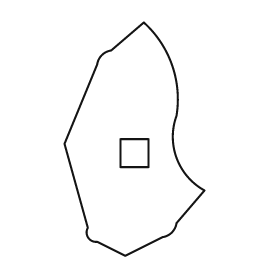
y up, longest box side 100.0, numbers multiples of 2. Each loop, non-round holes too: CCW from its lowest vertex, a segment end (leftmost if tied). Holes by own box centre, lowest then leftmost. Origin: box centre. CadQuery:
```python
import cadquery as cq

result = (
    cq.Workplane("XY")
    .moveTo(-4.0, -50.0)
    .lineTo(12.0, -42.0)
    .threePointArc((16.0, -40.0), (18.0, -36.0))
    .lineTo(30.0, -22.0)
    .threePointArc((18.0, -8.0), (18.0, 10.0))
    .threePointArc((16.0, 32.0), (4.0, 50.0))
    .lineTo(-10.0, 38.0)
    .threePointArc((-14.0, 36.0), (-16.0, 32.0))
    .lineTo(-30.0, -2.0)
    .lineTo(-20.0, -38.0)
    .threePointArc((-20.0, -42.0), (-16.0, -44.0))
    .close()
    .moveTo(-6.0, -12.0)
    .lineTo(6.0, -12.0)
    .lineTo(6.0, 0.0)
    .lineTo(-6.0, 0.0)
    .close()
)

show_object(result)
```